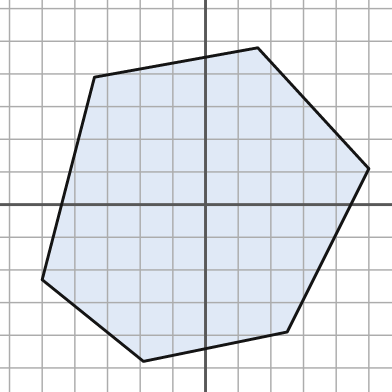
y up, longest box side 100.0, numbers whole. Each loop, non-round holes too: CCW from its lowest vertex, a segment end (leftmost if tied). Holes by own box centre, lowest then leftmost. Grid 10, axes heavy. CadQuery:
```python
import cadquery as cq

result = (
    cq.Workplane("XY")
    .moveTo(-19.0, -48.0)
    .lineTo(25.0, -39.0)
    .lineTo(50.0, 11.0)
    .lineTo(16.0, 48.0)
    .lineTo(-34.0, 39.0)
    .lineTo(-50.0, -23.0)
    .close()
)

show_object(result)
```